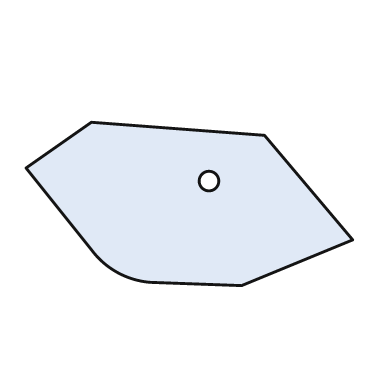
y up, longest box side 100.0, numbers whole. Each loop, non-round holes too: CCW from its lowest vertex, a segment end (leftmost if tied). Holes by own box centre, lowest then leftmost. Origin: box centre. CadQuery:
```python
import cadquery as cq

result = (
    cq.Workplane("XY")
    .moveTo(16.0, -25.0)
    .lineTo(50.0, -11.0)
    .lineTo(23.0, 21.0)
    .lineTo(-30.0, 25.0)
    .lineTo(-50.0, 11.0)
    .lineTo(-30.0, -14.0)
    .threePointArc((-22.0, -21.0), (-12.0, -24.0))
    .close()
    .moveTo(6.0, 7.0)
    .circle(3.0)
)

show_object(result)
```